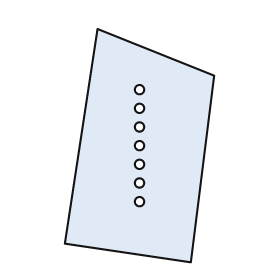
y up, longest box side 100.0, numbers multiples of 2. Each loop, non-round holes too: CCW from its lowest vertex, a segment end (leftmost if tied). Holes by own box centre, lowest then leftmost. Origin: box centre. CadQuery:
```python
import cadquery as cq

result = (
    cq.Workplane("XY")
    .moveTo(22.0, -50.0)
    .lineTo(32.0, 30.0)
    .lineTo(-18.0, 50.0)
    .lineTo(-32.0, -42.0)
    .close()
    .moveTo(0.0, -24.0)
    .circle(2.0)
    .moveTo(0.0, -16.0)
    .circle(2.0)
    .moveTo(0.0, -8.0)
    .circle(2.0)
    .moveTo(0.0, 0.0)
    .circle(2.0)
    .moveTo(0.0, 8.0)
    .circle(2.0)
    .moveTo(0.0, 16.0)
    .circle(2.0)
    .moveTo(0.0, 24.0)
    .circle(2.0)
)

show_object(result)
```